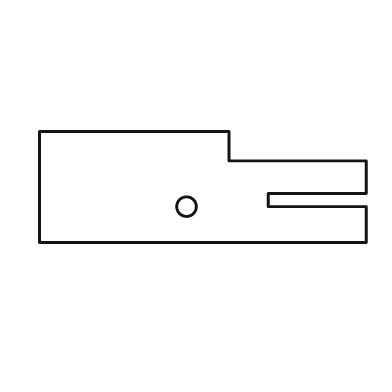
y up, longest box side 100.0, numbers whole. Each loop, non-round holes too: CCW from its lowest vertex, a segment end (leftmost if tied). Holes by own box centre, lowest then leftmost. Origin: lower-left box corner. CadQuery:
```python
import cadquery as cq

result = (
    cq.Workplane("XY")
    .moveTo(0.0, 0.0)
    .lineTo(100.0, 0.0)
    .lineTo(100.0, 11.0)
    .lineTo(70.0, 11.0)
    .lineTo(70.0, 15.0)
    .lineTo(100.0, 15.0)
    .lineTo(100.0, 25.0)
    .lineTo(58.0, 25.0)
    .lineTo(58.0, 34.0)
    .lineTo(0.0, 34.0)
    .close()
    .moveTo(45.0, 11.0)
    .circle(3.0)
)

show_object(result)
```